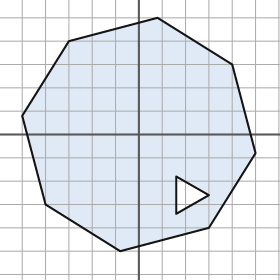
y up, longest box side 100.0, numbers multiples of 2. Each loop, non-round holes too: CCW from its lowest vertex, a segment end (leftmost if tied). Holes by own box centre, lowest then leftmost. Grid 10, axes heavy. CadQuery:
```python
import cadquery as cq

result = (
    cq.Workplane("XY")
    .moveTo(-8.0, -50.0)
    .lineTo(30.0, -40.0)
    .lineTo(50.0, -8.0)
    .lineTo(40.0, 30.0)
    .lineTo(8.0, 50.0)
    .lineTo(-30.0, 40.0)
    .lineTo(-50.0, 8.0)
    .lineTo(-40.0, -30.0)
    .close()
    .moveTo(16.0, -34.0)
    .lineTo(30.0, -26.0)
    .lineTo(16.0, -18.0)
    .close()
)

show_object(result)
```